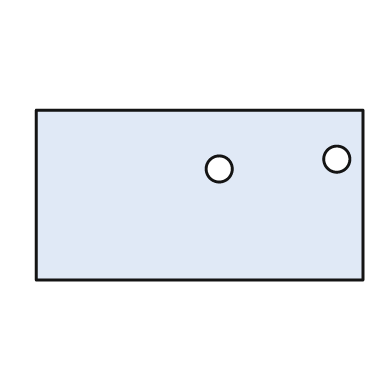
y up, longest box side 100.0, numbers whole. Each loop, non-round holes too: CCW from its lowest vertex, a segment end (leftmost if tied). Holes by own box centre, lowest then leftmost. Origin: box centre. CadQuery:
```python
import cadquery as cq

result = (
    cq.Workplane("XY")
    .moveTo(-50.0, -26.0)
    .lineTo(50.0, -26.0)
    .lineTo(50.0, 26.0)
    .lineTo(-50.0, 26.0)
    .close()
    .moveTo(6.0, 8.0)
    .circle(4.0)
    .moveTo(42.0, 11.0)
    .circle(4.0)
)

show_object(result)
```